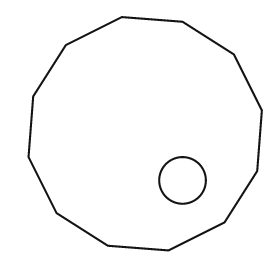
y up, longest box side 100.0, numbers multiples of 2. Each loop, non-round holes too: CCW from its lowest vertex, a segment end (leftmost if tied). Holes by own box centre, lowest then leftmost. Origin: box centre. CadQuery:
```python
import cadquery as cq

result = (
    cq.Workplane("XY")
    .moveTo(10.0, -50.0)
    .lineTo(34.0, -38.0)
    .lineTo(48.0, -16.0)
    .lineTo(50.0, 10.0)
    .lineTo(38.0, 34.0)
    .lineTo(16.0, 48.0)
    .lineTo(-10.0, 50.0)
    .lineTo(-34.0, 38.0)
    .lineTo(-48.0, 16.0)
    .lineTo(-50.0, -10.0)
    .lineTo(-38.0, -34.0)
    .lineTo(-16.0, -48.0)
    .close()
    .moveTo(16.0, -20.0)
    .circle(10.0)
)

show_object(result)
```